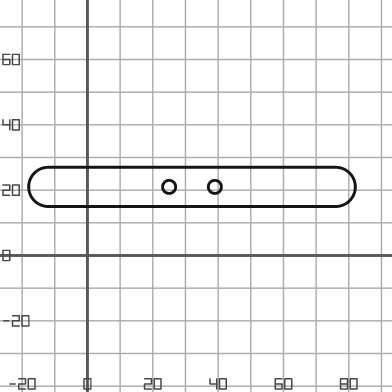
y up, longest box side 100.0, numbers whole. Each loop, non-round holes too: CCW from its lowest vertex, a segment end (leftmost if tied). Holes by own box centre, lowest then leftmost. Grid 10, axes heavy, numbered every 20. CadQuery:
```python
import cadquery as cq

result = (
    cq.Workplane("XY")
    .moveTo(-12.0, 15.0)
    .lineTo(76.0, 15.0)
    .threePointArc((82.0, 21.0), (76.0, 27.0))
    .lineTo(-12.0, 27.0)
    .threePointArc((-18.0, 21.0), (-12.0, 15.0))
    .close()
    .moveTo(25.0, 21.0)
    .circle(2.0)
    .moveTo(39.0, 21.0)
    .circle(2.0)
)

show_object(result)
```